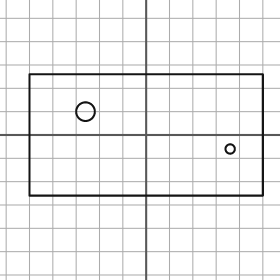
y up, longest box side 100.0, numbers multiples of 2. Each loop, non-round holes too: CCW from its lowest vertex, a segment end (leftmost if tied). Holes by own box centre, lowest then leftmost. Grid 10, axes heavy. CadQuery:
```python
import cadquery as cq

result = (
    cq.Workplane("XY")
    .moveTo(-50.0, -26.0)
    .lineTo(50.0, -26.0)
    .lineTo(50.0, 26.0)
    .lineTo(-50.0, 26.0)
    .close()
    .moveTo(36.0, -6.0)
    .circle(2.0)
    .moveTo(-26.0, 10.0)
    .circle(4.0)
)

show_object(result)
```